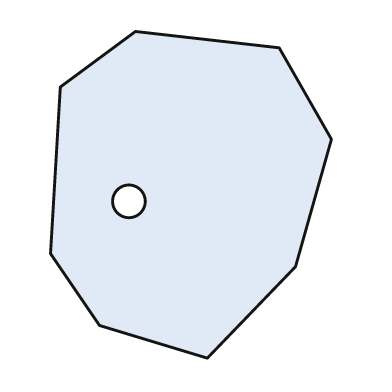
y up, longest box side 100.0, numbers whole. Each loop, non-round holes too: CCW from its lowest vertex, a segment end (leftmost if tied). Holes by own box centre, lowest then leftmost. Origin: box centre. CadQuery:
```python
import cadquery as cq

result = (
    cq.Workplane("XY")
    .moveTo(5.0, -50.0)
    .lineTo(32.0, -22.0)
    .lineTo(43.0, 17.0)
    .lineTo(27.0, 45.0)
    .lineTo(-17.0, 50.0)
    .lineTo(-40.0, 33.0)
    .lineTo(-43.0, -18.0)
    .lineTo(-28.0, -40.0)
    .close()
    .moveTo(-19.0, -2.0)
    .circle(5.0)
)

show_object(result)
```